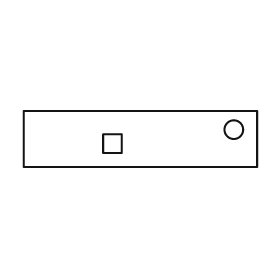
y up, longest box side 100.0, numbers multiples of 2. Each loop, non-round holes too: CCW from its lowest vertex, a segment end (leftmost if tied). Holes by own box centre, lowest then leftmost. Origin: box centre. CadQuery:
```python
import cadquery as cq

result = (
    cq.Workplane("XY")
    .moveTo(-50.0, -12.0)
    .lineTo(50.0, -12.0)
    .lineTo(50.0, 12.0)
    .lineTo(-50.0, 12.0)
    .close()
    .moveTo(-16.0, -6.0)
    .lineTo(-8.0, -6.0)
    .lineTo(-8.0, 2.0)
    .lineTo(-16.0, 2.0)
    .close()
    .moveTo(40.0, 4.0)
    .circle(4.0)
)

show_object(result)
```